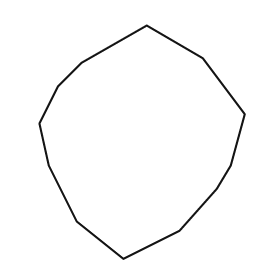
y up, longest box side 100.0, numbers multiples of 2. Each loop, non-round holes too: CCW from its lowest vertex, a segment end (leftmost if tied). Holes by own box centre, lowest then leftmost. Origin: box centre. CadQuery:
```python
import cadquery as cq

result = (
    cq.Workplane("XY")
    .moveTo(-8.0, -50.0)
    .lineTo(16.0, -38.0)
    .lineTo(32.0, -20.0)
    .lineTo(38.0, -10.0)
    .lineTo(44.0, 12.0)
    .lineTo(26.0, 36.0)
    .lineTo(2.0, 50.0)
    .lineTo(-26.0, 34.0)
    .lineTo(-36.0, 24.0)
    .lineTo(-44.0, 8.0)
    .lineTo(-40.0, -10.0)
    .lineTo(-28.0, -34.0)
    .close()
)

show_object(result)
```